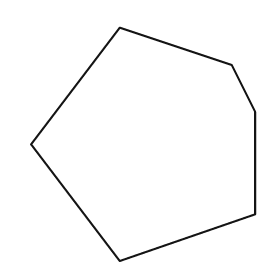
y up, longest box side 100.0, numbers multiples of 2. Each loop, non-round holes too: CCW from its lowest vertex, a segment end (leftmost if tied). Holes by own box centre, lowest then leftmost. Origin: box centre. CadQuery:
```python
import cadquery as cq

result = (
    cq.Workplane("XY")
    .moveTo(-10.0, -50.0)
    .lineTo(48.0, -30.0)
    .lineTo(48.0, 14.0)
    .lineTo(38.0, 34.0)
    .lineTo(-10.0, 50.0)
    .lineTo(-48.0, 0.0)
    .close()
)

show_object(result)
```